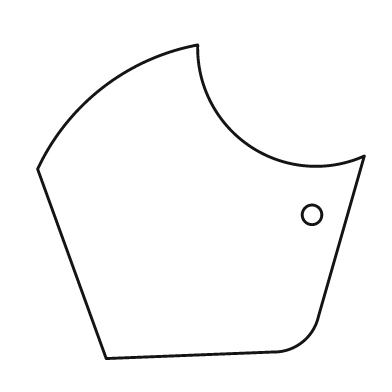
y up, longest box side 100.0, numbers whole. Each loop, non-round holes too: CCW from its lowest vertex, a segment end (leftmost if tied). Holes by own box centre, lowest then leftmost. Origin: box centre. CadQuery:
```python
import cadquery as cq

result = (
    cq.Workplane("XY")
    .moveTo(-29.0, -48.0)
    .lineTo(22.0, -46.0)
    .threePointArc((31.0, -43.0), (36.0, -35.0))
    .lineTo(50.0, 14.0)
    .threePointArc((15.0, 17.0), (-1.0, 48.0))
    .threePointArc((-30.0, 35.0), (-50.0, 10.0))
    .close()
    .moveTo(34.0, -4.0)
    .circle(3.0)
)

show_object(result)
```